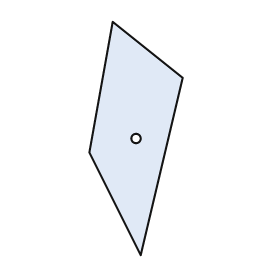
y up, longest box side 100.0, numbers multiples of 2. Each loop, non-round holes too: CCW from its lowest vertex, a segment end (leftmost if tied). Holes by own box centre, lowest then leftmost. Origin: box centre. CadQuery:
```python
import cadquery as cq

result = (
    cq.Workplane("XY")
    .moveTo(2.0, -50.0)
    .lineTo(20.0, 26.0)
    .lineTo(-10.0, 50.0)
    .lineTo(-20.0, -6.0)
    .close()
    .moveTo(0.0, 0.0)
    .circle(2.0)
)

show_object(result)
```